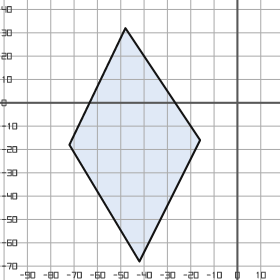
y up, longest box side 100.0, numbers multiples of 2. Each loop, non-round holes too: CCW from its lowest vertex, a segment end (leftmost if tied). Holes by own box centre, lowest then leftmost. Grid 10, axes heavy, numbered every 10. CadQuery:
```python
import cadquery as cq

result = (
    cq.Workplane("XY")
    .moveTo(-42.0, -68.0)
    .lineTo(-16.0, -16.0)
    .lineTo(-48.0, 32.0)
    .lineTo(-72.0, -18.0)
    .close()
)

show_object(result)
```